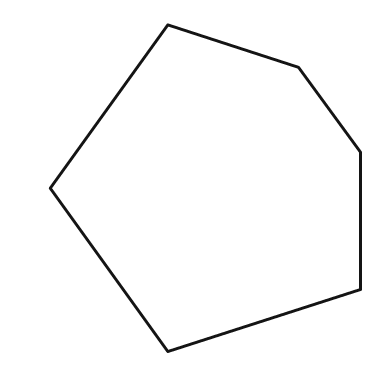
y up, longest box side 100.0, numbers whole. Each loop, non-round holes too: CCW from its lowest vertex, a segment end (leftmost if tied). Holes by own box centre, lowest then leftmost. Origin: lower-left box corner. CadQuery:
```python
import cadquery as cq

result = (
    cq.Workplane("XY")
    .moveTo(36.0, 0.0)
    .lineTo(95.0, 19.0)
    .lineTo(95.0, 61.0)
    .lineTo(76.0, 87.0)
    .lineTo(36.0, 100.0)
    .lineTo(0.0, 50.0)
    .close()
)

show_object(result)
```